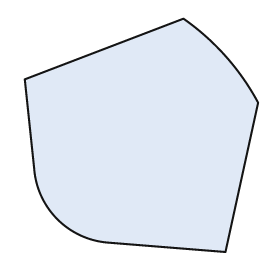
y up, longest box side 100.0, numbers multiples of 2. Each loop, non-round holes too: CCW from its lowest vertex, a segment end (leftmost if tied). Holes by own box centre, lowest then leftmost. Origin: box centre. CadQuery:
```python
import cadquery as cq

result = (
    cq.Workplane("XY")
    .moveTo(36.0, -50.0)
    .lineTo(50.0, 14.0)
    .threePointArc((36.0, 34.0), (18.0, 50.0))
    .lineTo(-50.0, 24.0)
    .lineTo(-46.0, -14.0)
    .threePointArc((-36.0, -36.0), (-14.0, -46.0))
    .close()
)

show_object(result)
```